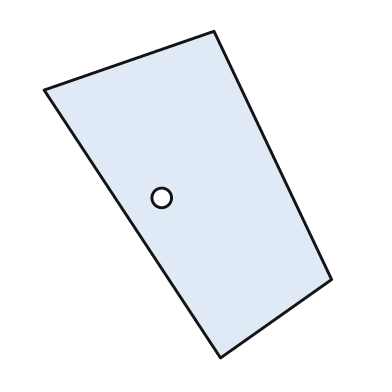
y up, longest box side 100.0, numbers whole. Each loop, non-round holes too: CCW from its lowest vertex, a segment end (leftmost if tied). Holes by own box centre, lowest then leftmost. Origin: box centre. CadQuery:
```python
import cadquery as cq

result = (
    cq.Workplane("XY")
    .moveTo(10.0, -50.0)
    .lineTo(44.0, -26.0)
    .lineTo(8.0, 50.0)
    .lineTo(-44.0, 32.0)
    .close()
    .moveTo(-8.0, -1.0)
    .circle(3.0)
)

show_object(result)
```